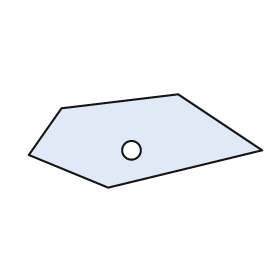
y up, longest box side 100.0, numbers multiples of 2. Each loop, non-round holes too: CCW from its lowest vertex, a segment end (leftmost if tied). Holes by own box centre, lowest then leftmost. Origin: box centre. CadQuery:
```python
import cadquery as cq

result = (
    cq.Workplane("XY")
    .moveTo(-16.0, -20.0)
    .lineTo(50.0, -4.0)
    .lineTo(14.0, 20.0)
    .lineTo(-36.0, 14.0)
    .lineTo(-50.0, -6.0)
    .close()
    .moveTo(-6.0, -4.0)
    .circle(4.0)
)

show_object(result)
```